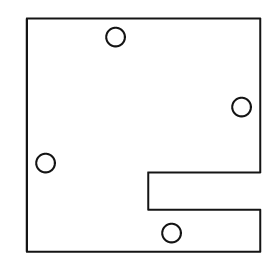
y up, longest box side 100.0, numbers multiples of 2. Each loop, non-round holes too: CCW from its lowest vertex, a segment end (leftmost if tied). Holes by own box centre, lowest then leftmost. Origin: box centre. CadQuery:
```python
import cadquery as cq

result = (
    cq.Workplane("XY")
    .moveTo(-50.0, -50.0)
    .lineTo(50.0, -50.0)
    .lineTo(50.0, -32.0)
    .lineTo(2.0, -32.0)
    .lineTo(2.0, -16.0)
    .lineTo(50.0, -16.0)
    .lineTo(50.0, 50.0)
    .lineTo(-50.0, 50.0)
    .close()
    .moveTo(12.0, -42.0)
    .circle(4.0)
    .moveTo(-42.0, -12.0)
    .circle(4.0)
    .moveTo(42.0, 12.0)
    .circle(4.0)
    .moveTo(-12.0, 42.0)
    .circle(4.0)
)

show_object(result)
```